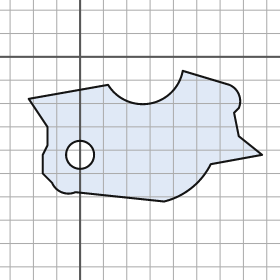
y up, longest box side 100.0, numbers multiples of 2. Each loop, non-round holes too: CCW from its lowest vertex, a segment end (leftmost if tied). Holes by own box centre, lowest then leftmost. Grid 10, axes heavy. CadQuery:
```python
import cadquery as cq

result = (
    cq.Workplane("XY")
    .moveTo(36.0, -62.0)
    .threePointArc((48.0, -56.0), (56.0, -46.0))
    .lineTo(78.0, -42.0)
    .lineTo(68.0, -34.0)
    .lineTo(66.0, -24.0)
    .lineTo(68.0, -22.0)
    .threePointArc((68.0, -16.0), (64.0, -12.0))
    .lineTo(44.0, -6.0)
    .threePointArc((30.0, -20.0), (12.0, -12.0))
    .lineTo(-22.0, -18.0)
    .lineTo(-14.0, -30.0)
    .lineTo(-14.0, -38.0)
    .lineTo(-16.0, -42.0)
    .lineTo(-16.0, -50.0)
    .lineTo(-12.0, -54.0)
    .threePointArc((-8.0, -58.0), (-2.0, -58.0))
    .close()
    .moveTo(0.0, -42.0)
    .circle(6.0)
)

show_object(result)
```